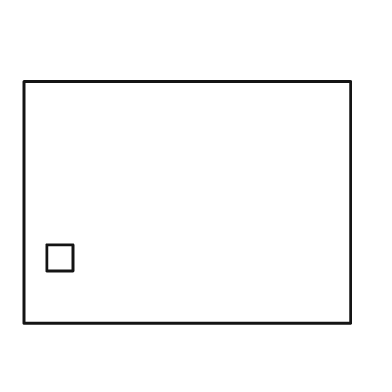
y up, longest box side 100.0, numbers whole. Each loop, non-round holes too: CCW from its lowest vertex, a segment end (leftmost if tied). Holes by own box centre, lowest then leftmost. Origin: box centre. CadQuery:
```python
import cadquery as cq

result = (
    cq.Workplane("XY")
    .moveTo(-50.0, -37.0)
    .lineTo(50.0, -37.0)
    .lineTo(50.0, 37.0)
    .lineTo(-50.0, 37.0)
    .close()
    .moveTo(-43.0, -21.0)
    .lineTo(-35.0, -21.0)
    .lineTo(-35.0, -13.0)
    .lineTo(-43.0, -13.0)
    .close()
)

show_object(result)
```